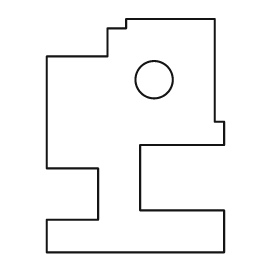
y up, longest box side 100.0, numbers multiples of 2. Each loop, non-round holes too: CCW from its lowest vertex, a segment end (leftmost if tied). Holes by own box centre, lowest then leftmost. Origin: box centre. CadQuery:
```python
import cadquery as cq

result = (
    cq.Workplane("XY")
    .moveTo(-38.0, -50.0)
    .lineTo(38.0, -50.0)
    .lineTo(38.0, -32.0)
    .lineTo(2.0, -32.0)
    .lineTo(2.0, -4.0)
    .lineTo(38.0, -4.0)
    .lineTo(38.0, 6.0)
    .lineTo(34.0, 6.0)
    .lineTo(34.0, 50.0)
    .lineTo(-4.0, 50.0)
    .lineTo(-4.0, 46.0)
    .lineTo(-12.0, 46.0)
    .lineTo(-12.0, 34.0)
    .lineTo(-38.0, 34.0)
    .lineTo(-38.0, -14.0)
    .lineTo(-16.0, -14.0)
    .lineTo(-16.0, -36.0)
    .lineTo(-38.0, -36.0)
    .close()
    .moveTo(8.0, 24.0)
    .circle(8.0)
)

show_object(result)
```